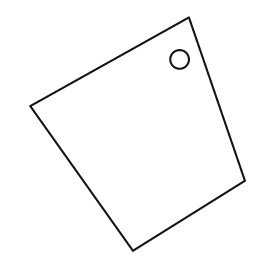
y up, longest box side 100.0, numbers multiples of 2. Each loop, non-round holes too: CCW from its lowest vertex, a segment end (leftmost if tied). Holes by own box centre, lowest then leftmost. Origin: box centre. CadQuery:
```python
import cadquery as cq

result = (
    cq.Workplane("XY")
    .moveTo(-2.0, -50.0)
    .lineTo(46.0, -20.0)
    .lineTo(22.0, 50.0)
    .lineTo(-46.0, 12.0)
    .close()
    .moveTo(18.0, 32.0)
    .circle(4.0)
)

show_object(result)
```